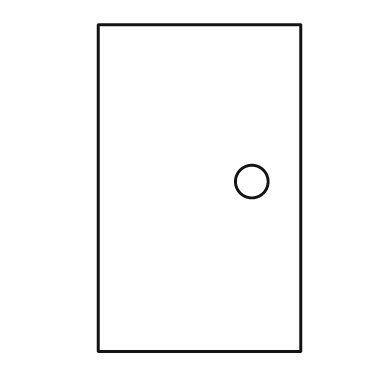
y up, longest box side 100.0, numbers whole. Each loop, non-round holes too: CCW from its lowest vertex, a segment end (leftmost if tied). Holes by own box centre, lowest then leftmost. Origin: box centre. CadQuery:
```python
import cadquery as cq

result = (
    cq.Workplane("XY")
    .moveTo(-31.0, -50.0)
    .lineTo(31.0, -50.0)
    .lineTo(31.0, 50.0)
    .lineTo(-31.0, 50.0)
    .close()
    .moveTo(16.0, 2.0)
    .circle(5.0)
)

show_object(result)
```